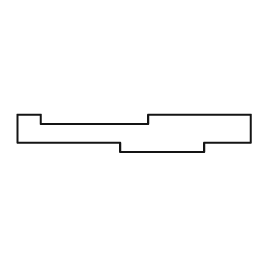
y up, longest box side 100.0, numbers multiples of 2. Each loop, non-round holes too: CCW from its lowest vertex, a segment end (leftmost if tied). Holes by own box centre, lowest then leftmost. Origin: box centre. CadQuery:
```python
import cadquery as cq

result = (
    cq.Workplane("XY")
    .moveTo(-6.0, -8.0)
    .lineTo(30.0, -8.0)
    .lineTo(30.0, -4.0)
    .lineTo(50.0, -4.0)
    .lineTo(50.0, 8.0)
    .lineTo(6.0, 8.0)
    .lineTo(6.0, 4.0)
    .lineTo(-40.0, 4.0)
    .lineTo(-40.0, 8.0)
    .lineTo(-50.0, 8.0)
    .lineTo(-50.0, -4.0)
    .lineTo(-6.0, -4.0)
    .close()
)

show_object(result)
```